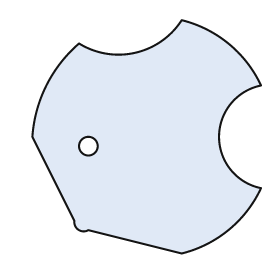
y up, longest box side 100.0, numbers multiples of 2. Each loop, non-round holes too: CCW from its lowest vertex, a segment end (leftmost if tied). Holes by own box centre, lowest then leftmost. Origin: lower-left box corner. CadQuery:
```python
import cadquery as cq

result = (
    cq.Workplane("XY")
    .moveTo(64.0, 0.0)
    .threePointArc((84.0, 10.0), (98.0, 28.0))
    .threePointArc((80.0, 50.0), (98.0, 72.0))
    .threePointArc((84.0, 90.0), (64.0, 100.0))
    .threePointArc((44.0, 86.0), (20.0, 90.0))
    .threePointArc((6.0, 72.0), (0.0, 50.0))
    .lineTo(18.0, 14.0)
    .threePointArc((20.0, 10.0), (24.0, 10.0))
    .close()
    .moveTo(24.0, 46.0)
    .circle(4.0)
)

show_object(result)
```